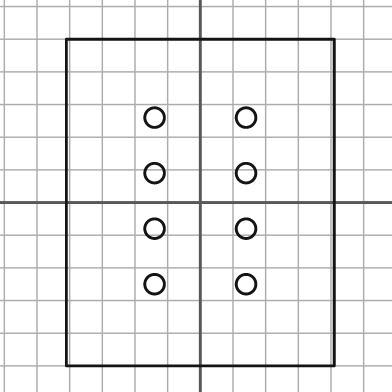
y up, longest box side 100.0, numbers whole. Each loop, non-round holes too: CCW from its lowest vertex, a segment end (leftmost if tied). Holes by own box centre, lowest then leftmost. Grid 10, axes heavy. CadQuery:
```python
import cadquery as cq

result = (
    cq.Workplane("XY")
    .moveTo(-41.0, -50.0)
    .lineTo(41.0, -50.0)
    .lineTo(41.0, 50.0)
    .lineTo(-41.0, 50.0)
    .close()
    .moveTo(-14.0, -25.0)
    .circle(3.0)
    .moveTo(14.0, -25.0)
    .circle(3.0)
    .moveTo(-14.0, -8.0)
    .circle(3.0)
    .moveTo(14.0, -8.0)
    .circle(3.0)
    .moveTo(-14.0, 9.0)
    .circle(3.0)
    .moveTo(14.0, 9.0)
    .circle(3.0)
    .moveTo(-14.0, 26.0)
    .circle(3.0)
    .moveTo(14.0, 26.0)
    .circle(3.0)
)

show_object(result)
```